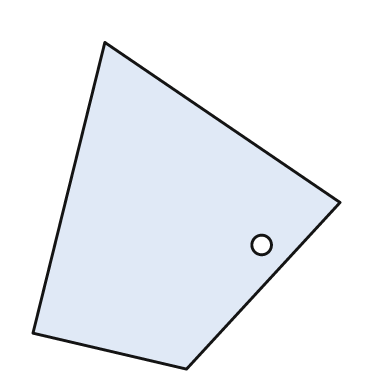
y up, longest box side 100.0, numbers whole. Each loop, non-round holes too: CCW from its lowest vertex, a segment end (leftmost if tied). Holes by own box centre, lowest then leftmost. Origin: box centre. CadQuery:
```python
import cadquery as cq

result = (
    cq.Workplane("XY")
    .moveTo(0.0, -50.0)
    .lineTo(47.0, 1.0)
    .lineTo(-25.0, 50.0)
    .lineTo(-47.0, -39.0)
    .close()
    .moveTo(23.0, -12.0)
    .circle(3.0)
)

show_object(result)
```